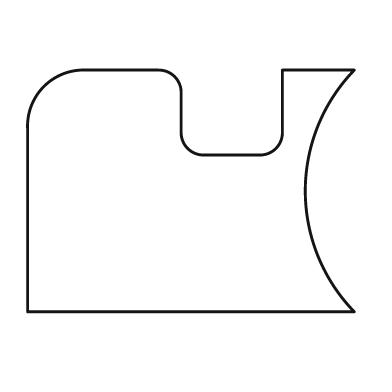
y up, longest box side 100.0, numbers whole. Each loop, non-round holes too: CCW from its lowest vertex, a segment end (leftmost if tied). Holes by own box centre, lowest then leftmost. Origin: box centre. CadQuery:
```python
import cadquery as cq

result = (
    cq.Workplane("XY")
    .moveTo(-50.0, -37.0)
    .lineTo(50.0, -37.0)
    .threePointArc((35.0, 0.0), (50.0, 37.0))
    .lineTo(28.0, 37.0)
    .lineTo(28.0, 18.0)
    .threePointArc((26.0, 13.0), (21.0, 11.0))
    .lineTo(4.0, 11.0)
    .threePointArc((-1.0, 13.0), (-3.0, 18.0))
    .lineTo(-3.0, 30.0)
    .threePointArc((-5.0, 35.0), (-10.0, 37.0))
    .lineTo(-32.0, 37.0)
    .threePointArc((-45.0, 32.0), (-50.0, 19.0))
    .close()
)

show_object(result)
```